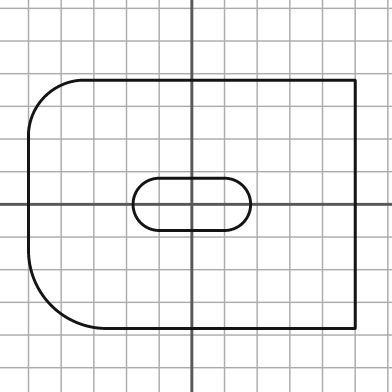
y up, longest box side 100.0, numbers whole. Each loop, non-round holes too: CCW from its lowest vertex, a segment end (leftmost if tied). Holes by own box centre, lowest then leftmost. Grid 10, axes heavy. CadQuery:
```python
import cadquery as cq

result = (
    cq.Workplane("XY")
    .moveTo(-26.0, -38.0)
    .lineTo(50.0, -38.0)
    .lineTo(50.0, 38.0)
    .lineTo(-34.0, 38.0)
    .threePointArc((-45.0, 33.0), (-50.0, 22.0))
    .lineTo(-50.0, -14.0)
    .threePointArc((-43.0, -31.0), (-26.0, -38.0))
    .close()
    .moveTo(-10.0, -8.0)
    .lineTo(10.0, -8.0)
    .threePointArc((18.0, 0.0), (10.0, 8.0))
    .lineTo(-10.0, 8.0)
    .threePointArc((-18.0, 0.0), (-10.0, -8.0))
    .close()
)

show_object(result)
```